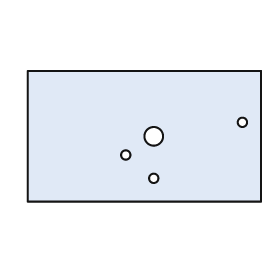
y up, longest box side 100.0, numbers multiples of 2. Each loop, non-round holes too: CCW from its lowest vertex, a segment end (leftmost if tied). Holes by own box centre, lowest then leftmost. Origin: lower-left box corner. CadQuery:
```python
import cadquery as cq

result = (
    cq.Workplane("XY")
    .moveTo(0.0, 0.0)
    .lineTo(100.0, 0.0)
    .lineTo(100.0, 56.0)
    .lineTo(0.0, 56.0)
    .close()
    .moveTo(54.0, 10.0)
    .circle(2.0)
    .moveTo(42.0, 20.0)
    .circle(2.0)
    .moveTo(54.0, 28.0)
    .circle(4.0)
    .moveTo(92.0, 34.0)
    .circle(2.0)
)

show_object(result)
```